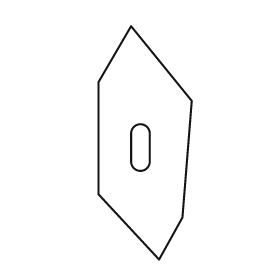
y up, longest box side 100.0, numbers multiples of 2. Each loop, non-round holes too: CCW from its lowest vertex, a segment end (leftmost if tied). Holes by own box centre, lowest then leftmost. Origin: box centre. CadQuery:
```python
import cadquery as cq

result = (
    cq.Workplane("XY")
    .moveTo(6.0, -50.0)
    .lineTo(16.0, -32.0)
    .lineTo(20.0, 18.0)
    .lineTo(-6.0, 50.0)
    .lineTo(-20.0, 26.0)
    .lineTo(-20.0, -22.0)
    .close()
    .moveTo(-6.0, -8.0)
    .threePointArc((-2.0, -12.0), (2.0, -8.0))
    .lineTo(2.0, 4.0)
    .threePointArc((-2.0, 8.0), (-6.0, 4.0))
    .close()
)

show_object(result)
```